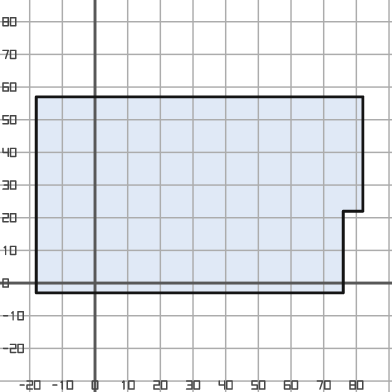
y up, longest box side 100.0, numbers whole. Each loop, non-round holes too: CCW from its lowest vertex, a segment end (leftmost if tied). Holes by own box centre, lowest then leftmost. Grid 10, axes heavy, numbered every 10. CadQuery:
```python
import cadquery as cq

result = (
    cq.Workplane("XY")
    .moveTo(-18.0, -3.0)
    .lineTo(76.0, -3.0)
    .lineTo(76.0, 22.0)
    .lineTo(82.0, 22.0)
    .lineTo(82.0, 57.0)
    .lineTo(-18.0, 57.0)
    .close()
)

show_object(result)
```